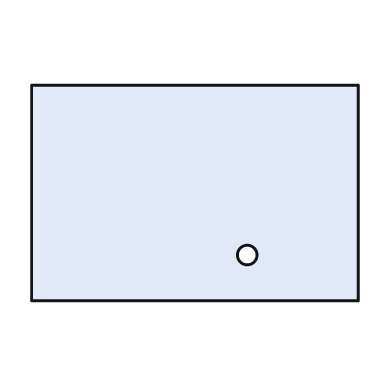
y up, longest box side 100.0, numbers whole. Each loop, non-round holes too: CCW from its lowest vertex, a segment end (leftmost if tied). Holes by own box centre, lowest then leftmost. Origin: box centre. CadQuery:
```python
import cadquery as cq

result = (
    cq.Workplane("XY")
    .moveTo(-50.0, -33.0)
    .lineTo(50.0, -33.0)
    .lineTo(50.0, 33.0)
    .lineTo(-50.0, 33.0)
    .close()
    .moveTo(16.0, -19.0)
    .circle(3.0)
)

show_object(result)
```